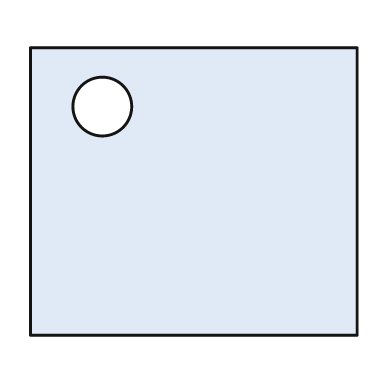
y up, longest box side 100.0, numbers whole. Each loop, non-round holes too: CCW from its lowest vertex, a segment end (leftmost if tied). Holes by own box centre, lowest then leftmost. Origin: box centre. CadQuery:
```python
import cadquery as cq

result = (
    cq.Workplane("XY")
    .moveTo(-50.0, -44.0)
    .lineTo(50.0, -44.0)
    .lineTo(50.0, 44.0)
    .lineTo(-50.0, 44.0)
    .close()
    .moveTo(-28.0, 26.0)
    .circle(9.0)
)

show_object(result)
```